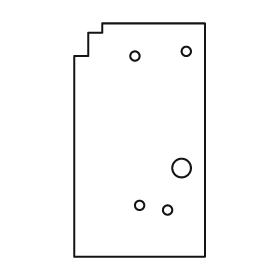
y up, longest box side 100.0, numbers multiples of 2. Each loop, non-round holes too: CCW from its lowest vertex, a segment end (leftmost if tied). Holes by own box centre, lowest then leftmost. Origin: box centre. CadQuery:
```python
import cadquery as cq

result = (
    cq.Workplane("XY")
    .moveTo(-28.0, -50.0)
    .lineTo(28.0, -50.0)
    .lineTo(28.0, 50.0)
    .lineTo(-16.0, 50.0)
    .lineTo(-16.0, 46.0)
    .lineTo(-22.0, 46.0)
    .lineTo(-22.0, 36.0)
    .lineTo(-28.0, 36.0)
    .close()
    .moveTo(12.0, -30.0)
    .circle(2.0)
    .moveTo(0.0, -28.0)
    .circle(2.0)
    .moveTo(18.0, -12.0)
    .circle(4.0)
    .moveTo(-2.0, 36.0)
    .circle(2.0)
    .moveTo(20.0, 38.0)
    .circle(2.0)
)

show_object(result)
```